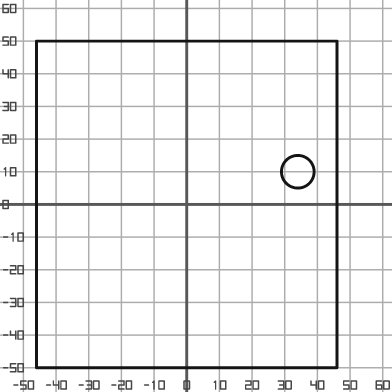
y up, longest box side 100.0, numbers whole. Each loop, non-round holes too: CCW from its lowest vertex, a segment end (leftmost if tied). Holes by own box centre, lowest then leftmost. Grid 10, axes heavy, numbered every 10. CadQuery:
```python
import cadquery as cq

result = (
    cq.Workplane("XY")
    .moveTo(-46.0, -50.0)
    .lineTo(46.0, -50.0)
    .lineTo(46.0, 50.0)
    .lineTo(-46.0, 50.0)
    .close()
    .moveTo(34.0, 10.0)
    .circle(5.0)
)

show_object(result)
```